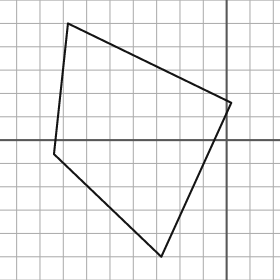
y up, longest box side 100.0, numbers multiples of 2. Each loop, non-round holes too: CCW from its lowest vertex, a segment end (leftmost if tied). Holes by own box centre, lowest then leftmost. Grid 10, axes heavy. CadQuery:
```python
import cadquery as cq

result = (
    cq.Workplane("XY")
    .moveTo(-28.0, -50.0)
    .lineTo(2.0, 16.0)
    .lineTo(-68.0, 50.0)
    .lineTo(-74.0, -6.0)
    .close()
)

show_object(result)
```